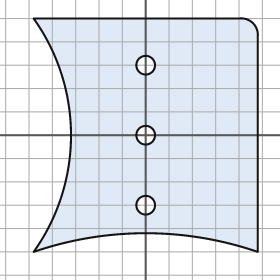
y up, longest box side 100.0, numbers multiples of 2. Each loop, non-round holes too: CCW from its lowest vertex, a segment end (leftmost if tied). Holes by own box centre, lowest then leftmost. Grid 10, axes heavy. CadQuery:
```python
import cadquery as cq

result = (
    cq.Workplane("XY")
    .moveTo(-48.0, -50.0)
    .threePointArc((0.0, -42.0), (48.0, -50.0))
    .lineTo(48.0, 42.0)
    .threePointArc((46.0, 48.0), (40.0, 50.0))
    .lineTo(-48.0, 50.0)
    .threePointArc((-32.0, 0.0), (-48.0, -50.0))
    .close()
    .moveTo(0.0, -30.0)
    .circle(4.0)
    .moveTo(0.0, 0.0)
    .circle(4.0)
    .moveTo(0.0, 30.0)
    .circle(4.0)
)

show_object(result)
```